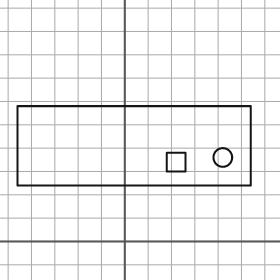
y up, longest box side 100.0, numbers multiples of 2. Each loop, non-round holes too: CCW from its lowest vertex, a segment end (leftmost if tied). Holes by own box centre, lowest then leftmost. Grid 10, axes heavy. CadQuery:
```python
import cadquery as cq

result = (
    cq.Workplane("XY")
    .moveTo(-46.0, 24.0)
    .lineTo(54.0, 24.0)
    .lineTo(54.0, 58.0)
    .lineTo(-46.0, 58.0)
    .close()
    .moveTo(18.0, 30.0)
    .lineTo(26.0, 30.0)
    .lineTo(26.0, 38.0)
    .lineTo(18.0, 38.0)
    .close()
    .moveTo(42.0, 36.0)
    .circle(4.0)
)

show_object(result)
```